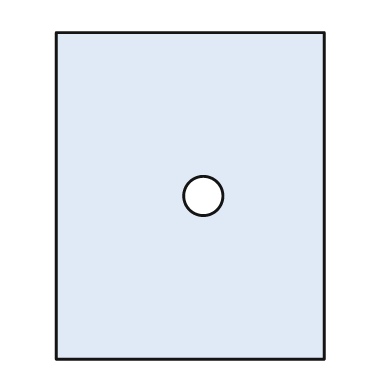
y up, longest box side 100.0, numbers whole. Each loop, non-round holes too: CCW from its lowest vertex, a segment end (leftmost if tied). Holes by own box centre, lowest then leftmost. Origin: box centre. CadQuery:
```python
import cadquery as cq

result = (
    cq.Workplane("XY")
    .moveTo(-41.0, -50.0)
    .lineTo(41.0, -50.0)
    .lineTo(41.0, 50.0)
    .lineTo(-41.0, 50.0)
    .close()
    .moveTo(4.0, 0.0)
    .circle(6.0)
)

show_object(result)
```